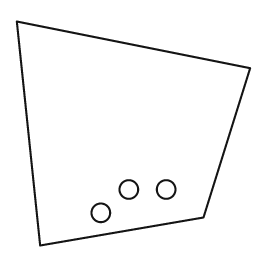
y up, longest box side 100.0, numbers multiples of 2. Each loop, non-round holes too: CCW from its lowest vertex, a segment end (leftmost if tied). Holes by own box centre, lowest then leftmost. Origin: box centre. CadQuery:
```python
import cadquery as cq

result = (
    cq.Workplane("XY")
    .moveTo(-40.0, -48.0)
    .lineTo(30.0, -36.0)
    .lineTo(50.0, 28.0)
    .lineTo(-50.0, 48.0)
    .close()
    .moveTo(-14.0, -34.0)
    .circle(4.0)
    .moveTo(-2.0, -24.0)
    .circle(4.0)
    .moveTo(14.0, -24.0)
    .circle(4.0)
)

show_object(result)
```